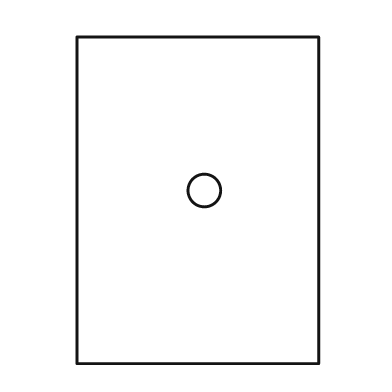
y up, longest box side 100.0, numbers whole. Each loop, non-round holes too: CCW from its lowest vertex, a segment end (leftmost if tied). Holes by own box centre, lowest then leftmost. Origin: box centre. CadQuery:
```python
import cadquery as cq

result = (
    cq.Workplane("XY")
    .moveTo(-37.0, -50.0)
    .lineTo(37.0, -50.0)
    .lineTo(37.0, 50.0)
    .lineTo(-37.0, 50.0)
    .close()
    .moveTo(2.0, 3.0)
    .circle(5.0)
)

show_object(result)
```